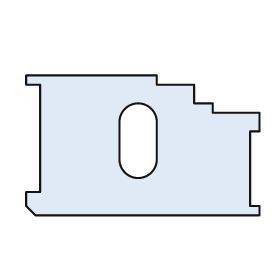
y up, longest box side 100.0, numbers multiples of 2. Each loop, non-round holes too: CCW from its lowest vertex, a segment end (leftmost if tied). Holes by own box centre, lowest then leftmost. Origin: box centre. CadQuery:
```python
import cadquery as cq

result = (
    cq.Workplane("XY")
    .moveTo(-46.0, -30.0)
    .lineTo(50.0, -30.0)
    .lineTo(50.0, -26.0)
    .lineTo(46.0, -26.0)
    .lineTo(46.0, 6.0)
    .lineTo(50.0, 6.0)
    .lineTo(50.0, 14.0)
    .lineTo(30.0, 14.0)
    .lineTo(30.0, 18.0)
    .lineTo(22.0, 18.0)
    .lineTo(22.0, 26.0)
    .lineTo(6.0, 26.0)
    .lineTo(6.0, 30.0)
    .lineTo(-50.0, 30.0)
    .lineTo(-50.0, 26.0)
    .lineTo(-44.0, 26.0)
    .lineTo(-44.0, -20.0)
    .lineTo(-50.0, -20.0)
    .lineTo(-50.0, -26.0)
    .close()
    .moveTo(-10.0, -6.0)
    .threePointArc((-2.0, -14.0), (6.0, -6.0))
    .lineTo(6.0, 10.0)
    .threePointArc((-2.0, 18.0), (-10.0, 10.0))
    .close()
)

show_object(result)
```